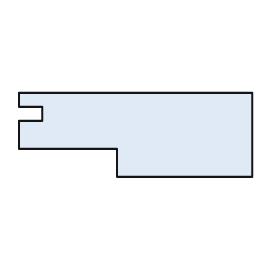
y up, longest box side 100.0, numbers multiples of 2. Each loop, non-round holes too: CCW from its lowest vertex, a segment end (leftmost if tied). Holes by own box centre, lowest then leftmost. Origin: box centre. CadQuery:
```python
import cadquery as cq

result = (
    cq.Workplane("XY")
    .moveTo(-8.0, -18.0)
    .lineTo(50.0, -18.0)
    .lineTo(50.0, 18.0)
    .lineTo(-50.0, 18.0)
    .lineTo(-50.0, 12.0)
    .lineTo(-40.0, 12.0)
    .lineTo(-40.0, 6.0)
    .lineTo(-50.0, 6.0)
    .lineTo(-50.0, -6.0)
    .lineTo(-8.0, -6.0)
    .close()
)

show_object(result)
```